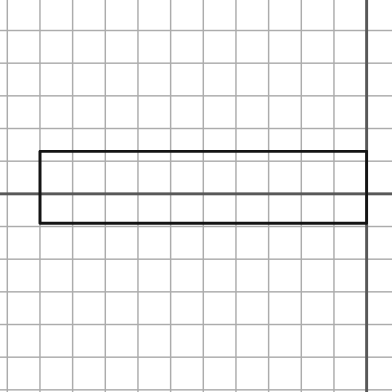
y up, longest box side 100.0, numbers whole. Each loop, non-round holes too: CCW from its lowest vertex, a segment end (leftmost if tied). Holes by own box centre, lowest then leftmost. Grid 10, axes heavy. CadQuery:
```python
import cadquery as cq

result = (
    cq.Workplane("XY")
    .moveTo(-100.0, -9.0)
    .lineTo(0.0, -9.0)
    .lineTo(0.0, 13.0)
    .lineTo(-100.0, 13.0)
    .close()
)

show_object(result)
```